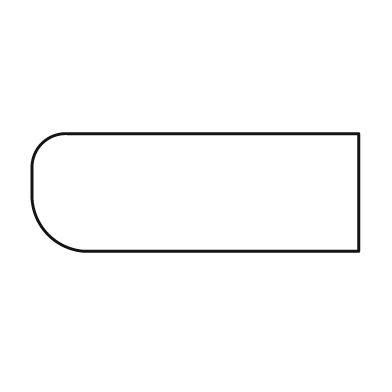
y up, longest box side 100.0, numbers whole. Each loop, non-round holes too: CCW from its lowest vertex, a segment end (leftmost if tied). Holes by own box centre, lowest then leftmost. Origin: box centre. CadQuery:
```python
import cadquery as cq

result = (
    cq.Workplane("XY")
    .moveTo(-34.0, -18.0)
    .lineTo(50.0, -18.0)
    .lineTo(50.0, 18.0)
    .lineTo(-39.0, 18.0)
    .threePointArc((-47.0, 15.0), (-50.0, 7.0))
    .lineTo(-50.0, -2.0)
    .threePointArc((-45.0, -13.0), (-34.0, -18.0))
    .close()
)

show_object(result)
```